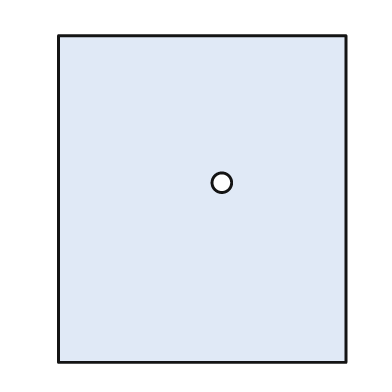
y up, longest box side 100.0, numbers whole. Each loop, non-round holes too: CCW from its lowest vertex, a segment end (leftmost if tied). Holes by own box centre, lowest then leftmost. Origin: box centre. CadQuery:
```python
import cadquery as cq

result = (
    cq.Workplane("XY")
    .moveTo(-44.0, -50.0)
    .lineTo(44.0, -50.0)
    .lineTo(44.0, 50.0)
    .lineTo(-44.0, 50.0)
    .close()
    .moveTo(6.0, 5.0)
    .circle(3.0)
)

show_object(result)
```